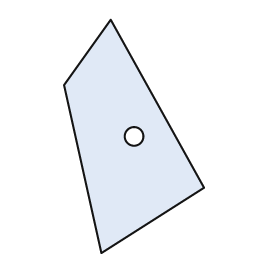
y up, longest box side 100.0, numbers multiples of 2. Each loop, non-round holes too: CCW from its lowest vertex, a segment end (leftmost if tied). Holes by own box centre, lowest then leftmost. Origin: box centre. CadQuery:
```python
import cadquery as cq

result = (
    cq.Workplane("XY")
    .moveTo(-14.0, -50.0)
    .lineTo(30.0, -22.0)
    .lineTo(-10.0, 50.0)
    .lineTo(-30.0, 22.0)
    .close()
    .moveTo(0.0, 0.0)
    .circle(4.0)
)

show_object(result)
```